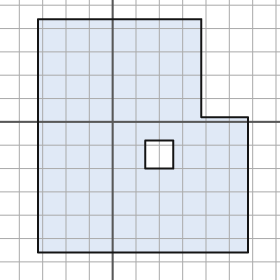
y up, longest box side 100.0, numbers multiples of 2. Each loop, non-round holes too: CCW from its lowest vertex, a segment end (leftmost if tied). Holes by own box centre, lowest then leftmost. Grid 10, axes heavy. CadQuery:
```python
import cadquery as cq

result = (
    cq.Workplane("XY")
    .moveTo(-32.0, -56.0)
    .lineTo(58.0, -56.0)
    .lineTo(58.0, 2.0)
    .lineTo(38.0, 2.0)
    .lineTo(38.0, 44.0)
    .lineTo(-32.0, 44.0)
    .close()
    .moveTo(14.0, -20.0)
    .lineTo(26.0, -20.0)
    .lineTo(26.0, -8.0)
    .lineTo(14.0, -8.0)
    .close()
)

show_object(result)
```